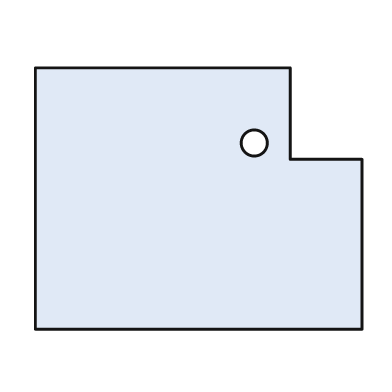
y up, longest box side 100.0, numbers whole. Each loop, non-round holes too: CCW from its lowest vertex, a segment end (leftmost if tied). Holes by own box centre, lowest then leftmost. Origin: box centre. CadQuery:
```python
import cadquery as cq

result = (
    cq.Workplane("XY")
    .moveTo(-50.0, -40.0)
    .lineTo(50.0, -40.0)
    .lineTo(50.0, 12.0)
    .lineTo(28.0, 12.0)
    .lineTo(28.0, 40.0)
    .lineTo(-50.0, 40.0)
    .close()
    .moveTo(17.0, 17.0)
    .circle(4.0)
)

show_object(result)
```